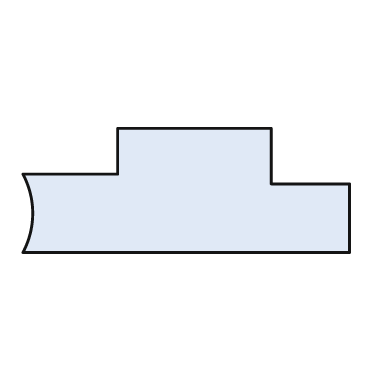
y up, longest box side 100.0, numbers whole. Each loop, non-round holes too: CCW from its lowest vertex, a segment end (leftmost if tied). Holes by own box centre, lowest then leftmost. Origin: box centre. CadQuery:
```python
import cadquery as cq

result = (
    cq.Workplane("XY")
    .moveTo(-50.0, -19.0)
    .lineTo(50.0, -19.0)
    .lineTo(50.0, 2.0)
    .lineTo(26.0, 2.0)
    .lineTo(26.0, 19.0)
    .lineTo(-21.0, 19.0)
    .lineTo(-21.0, 5.0)
    .lineTo(-50.0, 5.0)
    .threePointArc((-47.0, -7.0), (-50.0, -19.0))
    .close()
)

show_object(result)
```